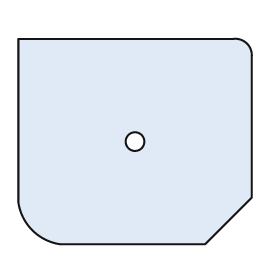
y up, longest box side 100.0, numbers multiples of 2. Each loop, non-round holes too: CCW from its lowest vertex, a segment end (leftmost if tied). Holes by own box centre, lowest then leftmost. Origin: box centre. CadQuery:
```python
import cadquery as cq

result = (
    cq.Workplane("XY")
    .moveTo(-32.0, -44.0)
    .lineTo(30.0, -44.0)
    .lineTo(50.0, -24.0)
    .lineTo(50.0, 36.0)
    .threePointArc((48.0, 42.0), (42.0, 44.0))
    .lineTo(-50.0, 44.0)
    .lineTo(-50.0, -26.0)
    .threePointArc((-44.0, -38.0), (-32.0, -44.0))
    .close()
    .moveTo(0.0, 0.0)
    .circle(4.0)
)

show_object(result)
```